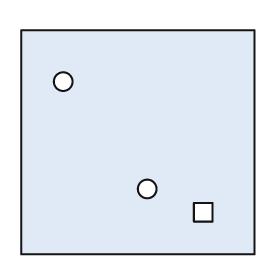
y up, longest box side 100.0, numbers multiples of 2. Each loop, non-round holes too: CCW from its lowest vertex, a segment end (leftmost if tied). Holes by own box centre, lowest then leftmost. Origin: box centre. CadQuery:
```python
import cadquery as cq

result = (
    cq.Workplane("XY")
    .moveTo(-50.0, -48.0)
    .lineTo(50.0, -48.0)
    .lineTo(50.0, 48.0)
    .lineTo(-50.0, 48.0)
    .close()
    .moveTo(24.0, -34.0)
    .lineTo(32.0, -34.0)
    .lineTo(32.0, -26.0)
    .lineTo(24.0, -26.0)
    .close()
    .moveTo(4.0, -20.0)
    .circle(4.0)
    .moveTo(-32.0, 26.0)
    .circle(4.0)
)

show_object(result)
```